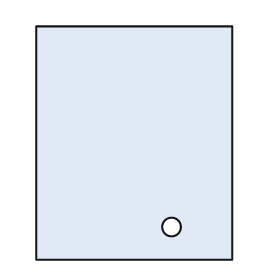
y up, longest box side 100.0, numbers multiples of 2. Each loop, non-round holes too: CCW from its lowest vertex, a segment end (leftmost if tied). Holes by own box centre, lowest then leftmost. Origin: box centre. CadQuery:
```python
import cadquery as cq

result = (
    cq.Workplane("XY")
    .moveTo(-42.0, -50.0)
    .lineTo(42.0, -50.0)
    .lineTo(42.0, 50.0)
    .lineTo(-42.0, 50.0)
    .close()
    .moveTo(16.0, -36.0)
    .circle(4.0)
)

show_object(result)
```